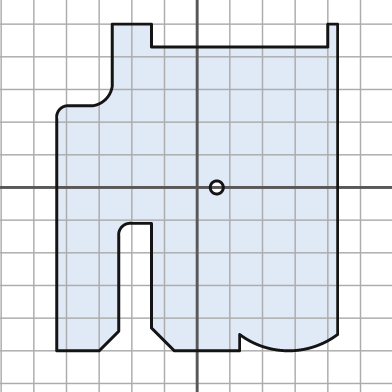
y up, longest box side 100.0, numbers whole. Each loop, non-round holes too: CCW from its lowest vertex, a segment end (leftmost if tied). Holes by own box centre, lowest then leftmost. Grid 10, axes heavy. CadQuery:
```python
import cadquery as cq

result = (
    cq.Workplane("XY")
    .moveTo(-43.0, -50.0)
    .lineTo(-30.0, -50.0)
    .lineTo(-24.0, -44.0)
    .lineTo(-24.0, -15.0)
    .threePointArc((-23.0, -12.0), (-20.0, -11.0))
    .lineTo(-14.0, -11.0)
    .lineTo(-14.0, -43.0)
    .lineTo(-7.0, -50.0)
    .lineTo(13.0, -50.0)
    .lineTo(13.0, -45.0)
    .threePointArc((28.0, -50.0), (43.0, -45.0))
    .lineTo(43.0, 50.0)
    .lineTo(40.0, 50.0)
    .lineTo(40.0, 43.0)
    .lineTo(-14.0, 43.0)
    .lineTo(-14.0, 50.0)
    .lineTo(-26.0, 50.0)
    .lineTo(-26.0, 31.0)
    .threePointArc((-28.0, 27.0), (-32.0, 25.0))
    .lineTo(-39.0, 25.0)
    .threePointArc((-42.0, 24.0), (-43.0, 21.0))
    .close()
    .moveTo(6.0, 0.0)
    .circle(2.0)
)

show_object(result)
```